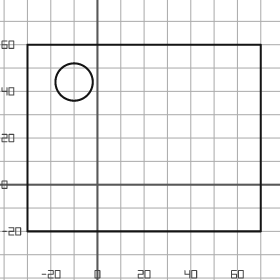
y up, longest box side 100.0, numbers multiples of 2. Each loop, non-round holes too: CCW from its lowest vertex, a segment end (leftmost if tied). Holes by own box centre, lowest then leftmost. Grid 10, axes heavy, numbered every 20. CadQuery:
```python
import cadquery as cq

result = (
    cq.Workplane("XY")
    .moveTo(-30.0, -20.0)
    .lineTo(70.0, -20.0)
    .lineTo(70.0, 60.0)
    .lineTo(-30.0, 60.0)
    .close()
    .moveTo(-10.0, 44.0)
    .circle(8.0)
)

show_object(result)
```